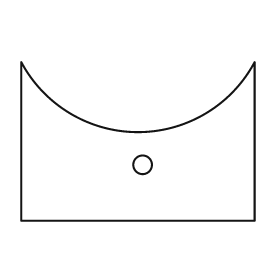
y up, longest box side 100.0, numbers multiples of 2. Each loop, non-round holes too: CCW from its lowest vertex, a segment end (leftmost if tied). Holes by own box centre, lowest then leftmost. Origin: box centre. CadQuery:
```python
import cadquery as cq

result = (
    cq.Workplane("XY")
    .moveTo(-50.0, -34.0)
    .lineTo(50.0, -34.0)
    .lineTo(50.0, 34.0)
    .threePointArc((0.0, 4.0), (-50.0, 34.0))
    .close()
    .moveTo(2.0, -10.0)
    .circle(4.0)
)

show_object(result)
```